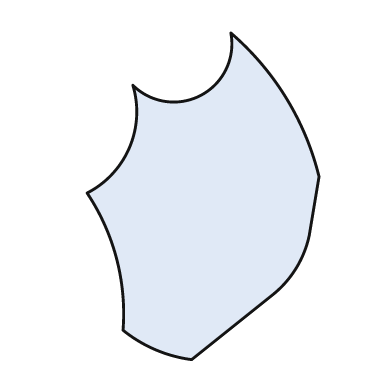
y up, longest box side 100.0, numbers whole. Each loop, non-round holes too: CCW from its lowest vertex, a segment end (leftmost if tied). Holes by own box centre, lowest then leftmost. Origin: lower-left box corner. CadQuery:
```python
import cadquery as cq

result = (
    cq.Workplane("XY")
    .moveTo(32.0, 0.0)
    .lineTo(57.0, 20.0)
    .threePointArc((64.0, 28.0), (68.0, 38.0))
    .lineTo(71.0, 56.0)
    .threePointArc((61.0, 80.0), (44.0, 100.0))
    .threePointArc((35.0, 81.0), (14.0, 84.0))
    .threePointArc((13.0, 65.0), (0.0, 51.0))
    .threePointArc((9.0, 31.0), (11.0, 9.0))
    .threePointArc((21.0, 3.0), (32.0, 0.0))
    .close()
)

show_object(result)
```